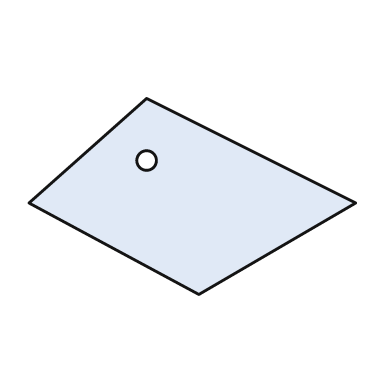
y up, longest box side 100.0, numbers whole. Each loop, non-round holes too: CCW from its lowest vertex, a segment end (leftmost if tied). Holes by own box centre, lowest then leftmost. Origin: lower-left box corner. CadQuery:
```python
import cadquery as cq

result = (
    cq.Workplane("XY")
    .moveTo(52.0, 0.0)
    .lineTo(100.0, 28.0)
    .lineTo(36.0, 60.0)
    .lineTo(0.0, 28.0)
    .close()
    .moveTo(36.0, 41.0)
    .circle(3.0)
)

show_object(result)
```